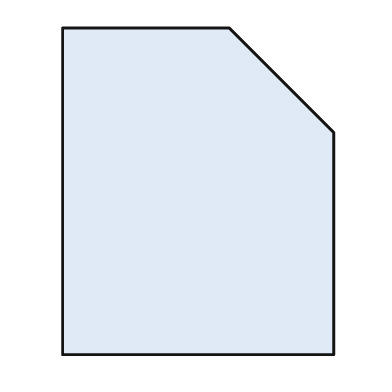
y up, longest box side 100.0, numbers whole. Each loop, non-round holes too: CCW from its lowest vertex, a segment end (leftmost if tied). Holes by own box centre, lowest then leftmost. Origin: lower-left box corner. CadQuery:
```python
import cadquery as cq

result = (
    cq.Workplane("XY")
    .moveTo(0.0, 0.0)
    .lineTo(83.0, 0.0)
    .lineTo(83.0, 68.0)
    .lineTo(51.0, 100.0)
    .lineTo(0.0, 100.0)
    .close()
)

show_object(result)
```